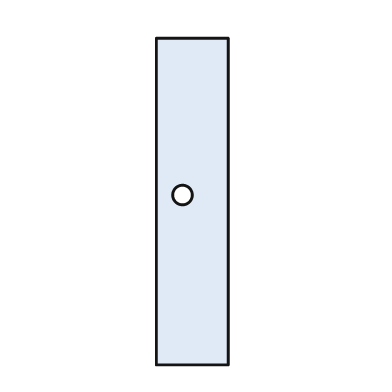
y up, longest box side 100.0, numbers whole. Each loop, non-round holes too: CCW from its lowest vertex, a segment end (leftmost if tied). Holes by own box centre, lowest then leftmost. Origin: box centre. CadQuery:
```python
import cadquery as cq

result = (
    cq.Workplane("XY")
    .moveTo(-11.0, -50.0)
    .lineTo(11.0, -50.0)
    .lineTo(11.0, 50.0)
    .lineTo(-11.0, 50.0)
    .close()
    .moveTo(-3.0, 2.0)
    .circle(3.0)
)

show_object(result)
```